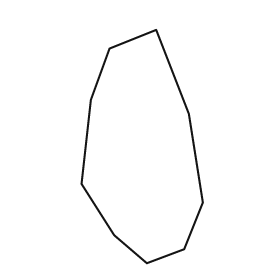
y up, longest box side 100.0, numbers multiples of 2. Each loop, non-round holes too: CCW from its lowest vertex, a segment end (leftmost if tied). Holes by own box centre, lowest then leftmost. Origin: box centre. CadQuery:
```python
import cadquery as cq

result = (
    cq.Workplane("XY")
    .moveTo(2.0, -50.0)
    .lineTo(18.0, -44.0)
    .lineTo(26.0, -24.0)
    .lineTo(20.0, 14.0)
    .lineTo(6.0, 50.0)
    .lineTo(-14.0, 42.0)
    .lineTo(-22.0, 20.0)
    .lineTo(-26.0, -16.0)
    .lineTo(-12.0, -38.0)
    .close()
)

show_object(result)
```